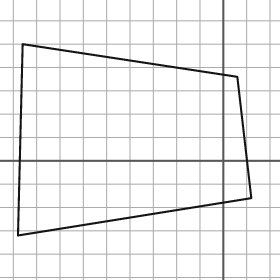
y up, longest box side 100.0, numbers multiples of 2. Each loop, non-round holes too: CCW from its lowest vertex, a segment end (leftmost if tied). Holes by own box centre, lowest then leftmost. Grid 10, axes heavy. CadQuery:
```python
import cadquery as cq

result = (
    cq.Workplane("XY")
    .moveTo(-88.0, -32.0)
    .lineTo(12.0, -16.0)
    .lineTo(6.0, 36.0)
    .lineTo(-86.0, 50.0)
    .close()
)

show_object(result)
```